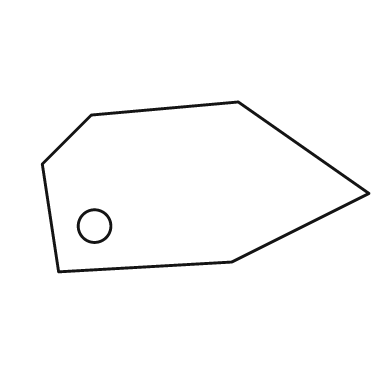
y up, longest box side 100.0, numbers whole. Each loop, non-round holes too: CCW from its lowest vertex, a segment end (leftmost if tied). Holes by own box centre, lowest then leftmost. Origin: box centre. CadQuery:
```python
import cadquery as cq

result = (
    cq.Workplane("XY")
    .moveTo(-45.0, -26.0)
    .lineTo(8.0, -23.0)
    .lineTo(50.0, -2.0)
    .lineTo(10.0, 26.0)
    .lineTo(-35.0, 22.0)
    .lineTo(-50.0, 7.0)
    .close()
    .moveTo(-34.0, -12.0)
    .circle(5.0)
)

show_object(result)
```